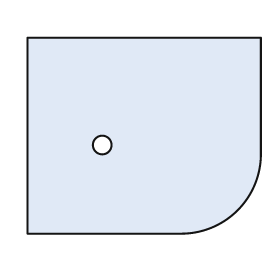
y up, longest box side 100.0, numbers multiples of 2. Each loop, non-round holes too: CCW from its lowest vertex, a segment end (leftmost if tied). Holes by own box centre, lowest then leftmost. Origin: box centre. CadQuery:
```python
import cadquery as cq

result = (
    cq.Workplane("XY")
    .moveTo(-50.0, -42.0)
    .lineTo(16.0, -42.0)
    .threePointArc((40.0, -32.0), (50.0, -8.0))
    .lineTo(50.0, 42.0)
    .lineTo(-50.0, 42.0)
    .close()
    .moveTo(-18.0, -4.0)
    .circle(4.0)
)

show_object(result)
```